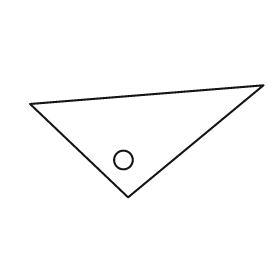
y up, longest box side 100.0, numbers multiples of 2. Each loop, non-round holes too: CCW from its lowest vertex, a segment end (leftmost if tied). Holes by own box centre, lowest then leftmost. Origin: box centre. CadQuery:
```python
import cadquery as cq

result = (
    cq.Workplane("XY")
    .moveTo(-8.0, -24.0)
    .lineTo(50.0, 24.0)
    .lineTo(-50.0, 16.0)
    .close()
    .moveTo(-10.0, -8.0)
    .circle(4.0)
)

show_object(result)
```